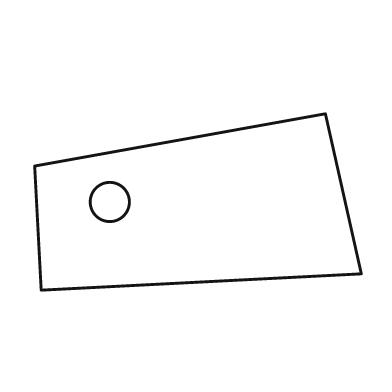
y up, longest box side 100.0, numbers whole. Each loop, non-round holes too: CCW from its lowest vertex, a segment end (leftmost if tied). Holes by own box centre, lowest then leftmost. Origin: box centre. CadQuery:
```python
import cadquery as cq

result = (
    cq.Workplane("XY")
    .moveTo(-48.0, -27.0)
    .lineTo(50.0, -22.0)
    .lineTo(39.0, 27.0)
    .lineTo(-50.0, 11.0)
    .close()
    .moveTo(-27.0, 0.0)
    .circle(6.0)
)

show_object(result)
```